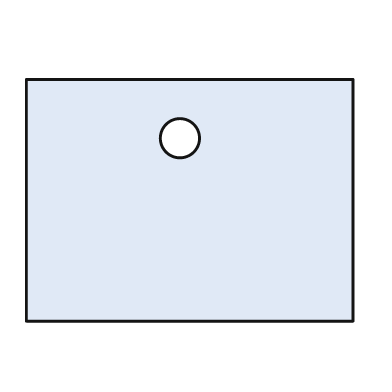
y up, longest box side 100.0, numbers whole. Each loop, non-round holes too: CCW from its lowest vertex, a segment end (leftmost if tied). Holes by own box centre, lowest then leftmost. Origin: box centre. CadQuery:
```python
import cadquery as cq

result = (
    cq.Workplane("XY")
    .moveTo(-50.0, -37.0)
    .lineTo(50.0, -37.0)
    .lineTo(50.0, 37.0)
    .lineTo(-50.0, 37.0)
    .close()
    .moveTo(-3.0, 19.0)
    .circle(6.0)
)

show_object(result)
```